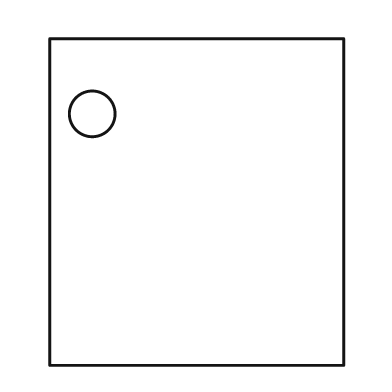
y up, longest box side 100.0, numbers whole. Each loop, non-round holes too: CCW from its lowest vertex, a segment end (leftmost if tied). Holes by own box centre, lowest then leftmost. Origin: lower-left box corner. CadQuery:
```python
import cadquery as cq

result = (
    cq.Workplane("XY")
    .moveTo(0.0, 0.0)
    .lineTo(90.0, 0.0)
    .lineTo(90.0, 100.0)
    .lineTo(0.0, 100.0)
    .close()
    .moveTo(13.0, 77.0)
    .circle(7.0)
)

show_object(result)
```